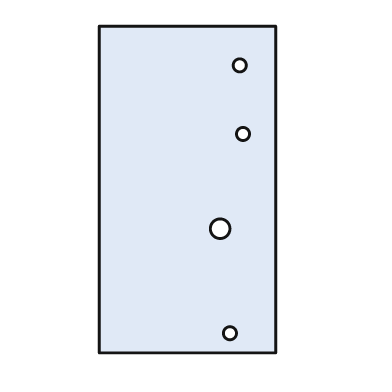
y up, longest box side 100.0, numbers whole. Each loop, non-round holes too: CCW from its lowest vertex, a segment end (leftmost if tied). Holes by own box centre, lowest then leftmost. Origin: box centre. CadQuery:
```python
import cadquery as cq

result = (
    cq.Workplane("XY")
    .moveTo(-27.0, -50.0)
    .lineTo(27.0, -50.0)
    .lineTo(27.0, 50.0)
    .lineTo(-27.0, 50.0)
    .close()
    .moveTo(13.0, -44.0)
    .circle(2.0)
    .moveTo(10.0, -12.0)
    .circle(3.0)
    .moveTo(17.0, 17.0)
    .circle(2.0)
    .moveTo(16.0, 38.0)
    .circle(2.0)
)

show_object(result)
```